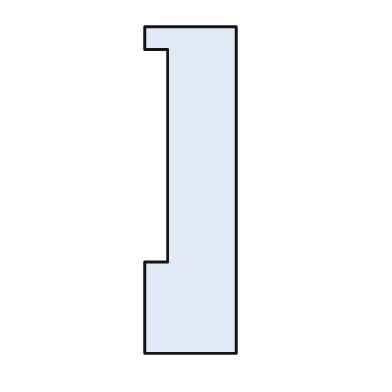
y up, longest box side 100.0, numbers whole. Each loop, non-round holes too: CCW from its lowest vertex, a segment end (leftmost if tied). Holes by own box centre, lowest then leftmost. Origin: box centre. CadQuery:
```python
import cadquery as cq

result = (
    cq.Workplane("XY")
    .moveTo(-14.0, -50.0)
    .lineTo(14.0, -50.0)
    .lineTo(14.0, 50.0)
    .lineTo(-14.0, 50.0)
    .lineTo(-14.0, 43.0)
    .lineTo(-7.0, 43.0)
    .lineTo(-7.0, -22.0)
    .lineTo(-14.0, -22.0)
    .close()
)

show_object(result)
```